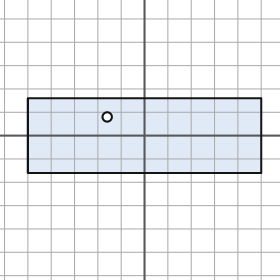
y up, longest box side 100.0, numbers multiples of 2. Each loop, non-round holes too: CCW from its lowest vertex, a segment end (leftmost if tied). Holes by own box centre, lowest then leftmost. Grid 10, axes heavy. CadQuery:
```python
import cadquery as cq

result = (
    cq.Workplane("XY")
    .moveTo(-50.0, -16.0)
    .lineTo(50.0, -16.0)
    .lineTo(50.0, 16.0)
    .lineTo(-50.0, 16.0)
    .close()
    .moveTo(-16.0, 8.0)
    .circle(2.0)
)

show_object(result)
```